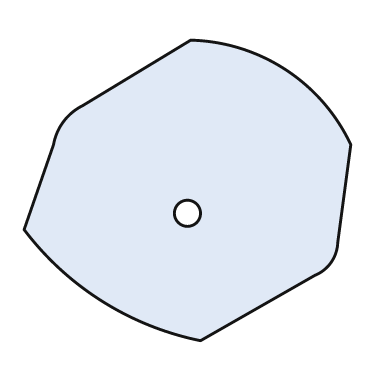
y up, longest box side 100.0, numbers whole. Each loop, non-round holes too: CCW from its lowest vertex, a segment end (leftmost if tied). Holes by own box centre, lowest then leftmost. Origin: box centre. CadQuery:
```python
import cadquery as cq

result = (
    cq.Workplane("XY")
    .moveTo(4.0, -46.0)
    .lineTo(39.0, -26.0)
    .threePointArc((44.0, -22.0), (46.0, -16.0))
    .lineTo(50.0, 14.0)
    .threePointArc((30.0, 37.0), (1.0, 46.0))
    .lineTo(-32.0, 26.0)
    .threePointArc((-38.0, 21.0), (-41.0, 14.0))
    .lineTo(-50.0, -12.0)
    .threePointArc((-26.0, -34.0), (4.0, -46.0))
    .close()
    .moveTo(0.0, -7.0)
    .circle(4.0)
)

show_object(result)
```